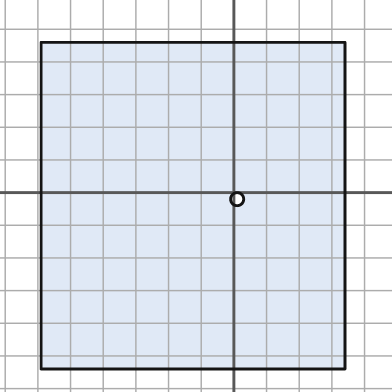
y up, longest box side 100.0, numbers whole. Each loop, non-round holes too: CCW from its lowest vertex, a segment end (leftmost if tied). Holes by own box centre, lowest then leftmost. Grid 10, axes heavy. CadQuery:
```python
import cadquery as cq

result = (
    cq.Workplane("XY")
    .moveTo(-59.0, -54.0)
    .lineTo(34.0, -54.0)
    .lineTo(34.0, 46.0)
    .lineTo(-59.0, 46.0)
    .close()
    .moveTo(1.0, -2.0)
    .circle(2.0)
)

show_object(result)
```